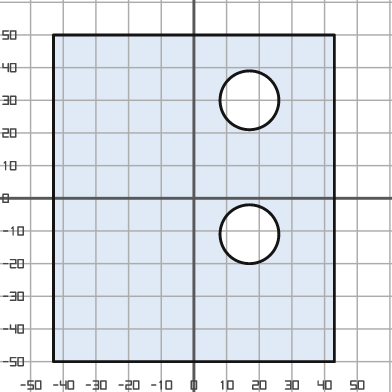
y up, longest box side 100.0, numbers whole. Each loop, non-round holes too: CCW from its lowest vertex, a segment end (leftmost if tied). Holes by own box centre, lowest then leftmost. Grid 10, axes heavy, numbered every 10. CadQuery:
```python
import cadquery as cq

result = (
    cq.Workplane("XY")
    .moveTo(-43.0, -50.0)
    .lineTo(43.0, -50.0)
    .lineTo(43.0, 50.0)
    .lineTo(-43.0, 50.0)
    .close()
    .moveTo(17.0, -11.0)
    .circle(9.0)
    .moveTo(17.0, 30.0)
    .circle(9.0)
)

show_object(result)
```